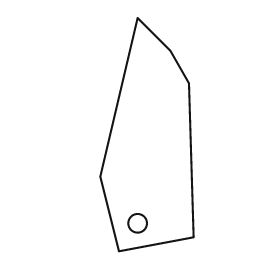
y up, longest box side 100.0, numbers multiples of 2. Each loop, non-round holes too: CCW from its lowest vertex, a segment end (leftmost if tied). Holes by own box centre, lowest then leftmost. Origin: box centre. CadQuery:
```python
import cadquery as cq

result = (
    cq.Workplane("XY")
    .moveTo(-12.0, -50.0)
    .lineTo(20.0, -44.0)
    .lineTo(18.0, 22.0)
    .lineTo(10.0, 36.0)
    .lineTo(-4.0, 50.0)
    .lineTo(-20.0, -18.0)
    .close()
    .moveTo(-4.0, -38.0)
    .circle(4.0)
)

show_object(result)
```